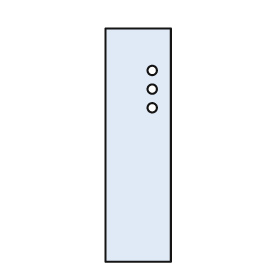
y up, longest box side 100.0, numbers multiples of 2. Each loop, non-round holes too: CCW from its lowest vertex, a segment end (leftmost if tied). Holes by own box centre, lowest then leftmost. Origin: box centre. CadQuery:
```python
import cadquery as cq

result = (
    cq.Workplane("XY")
    .moveTo(-14.0, -50.0)
    .lineTo(14.0, -50.0)
    .lineTo(14.0, 50.0)
    .lineTo(-14.0, 50.0)
    .close()
    .moveTo(6.0, 16.0)
    .circle(2.0)
    .moveTo(6.0, 24.0)
    .circle(2.0)
    .moveTo(6.0, 32.0)
    .circle(2.0)
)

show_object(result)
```